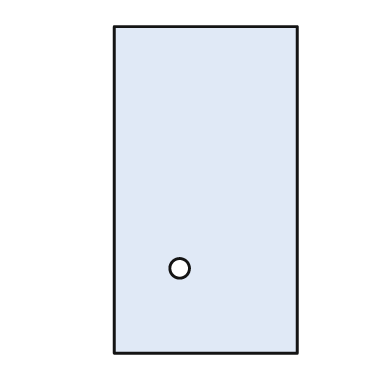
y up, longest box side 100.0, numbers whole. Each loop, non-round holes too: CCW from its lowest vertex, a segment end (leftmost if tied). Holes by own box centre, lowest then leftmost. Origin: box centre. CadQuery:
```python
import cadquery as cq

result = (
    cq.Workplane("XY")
    .moveTo(-28.0, -50.0)
    .lineTo(28.0, -50.0)
    .lineTo(28.0, 50.0)
    .lineTo(-28.0, 50.0)
    .close()
    .moveTo(-8.0, -24.0)
    .circle(3.0)
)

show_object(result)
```